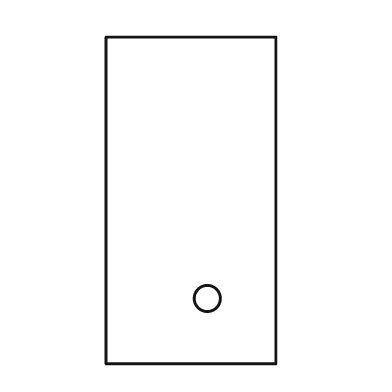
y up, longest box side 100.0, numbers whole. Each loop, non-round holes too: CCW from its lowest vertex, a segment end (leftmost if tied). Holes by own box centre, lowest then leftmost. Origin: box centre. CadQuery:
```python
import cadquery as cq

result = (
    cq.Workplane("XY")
    .moveTo(-26.0, -50.0)
    .lineTo(26.0, -50.0)
    .lineTo(26.0, 50.0)
    .lineTo(-26.0, 50.0)
    .close()
    .moveTo(5.0, -30.0)
    .circle(4.0)
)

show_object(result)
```